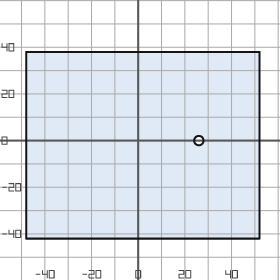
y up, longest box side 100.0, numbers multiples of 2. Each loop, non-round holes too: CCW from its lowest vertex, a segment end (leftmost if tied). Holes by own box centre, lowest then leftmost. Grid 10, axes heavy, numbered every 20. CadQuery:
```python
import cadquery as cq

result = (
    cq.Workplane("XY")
    .moveTo(-48.0, -42.0)
    .lineTo(52.0, -42.0)
    .lineTo(52.0, 38.0)
    .lineTo(-48.0, 38.0)
    .close()
    .moveTo(26.0, 0.0)
    .circle(2.0)
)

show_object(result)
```